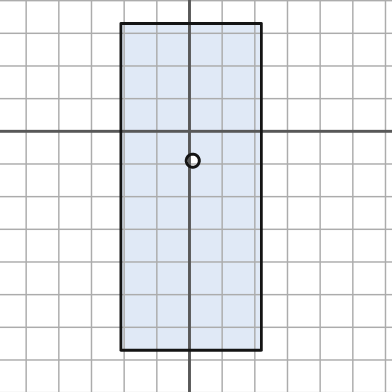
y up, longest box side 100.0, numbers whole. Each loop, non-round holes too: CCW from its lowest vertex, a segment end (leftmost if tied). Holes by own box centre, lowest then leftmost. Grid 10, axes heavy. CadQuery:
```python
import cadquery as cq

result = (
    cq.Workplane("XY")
    .moveTo(-21.0, -67.0)
    .lineTo(22.0, -67.0)
    .lineTo(22.0, 33.0)
    .lineTo(-21.0, 33.0)
    .close()
    .moveTo(1.0, -9.0)
    .circle(2.0)
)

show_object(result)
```